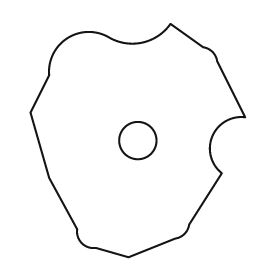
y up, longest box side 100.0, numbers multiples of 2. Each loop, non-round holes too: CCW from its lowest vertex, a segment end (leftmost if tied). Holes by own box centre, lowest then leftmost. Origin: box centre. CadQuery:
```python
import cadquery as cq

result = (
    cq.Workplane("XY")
    .moveTo(-4.0, -50.0)
    .lineTo(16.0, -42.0)
    .threePointArc((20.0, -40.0), (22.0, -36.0))
    .lineTo(36.0, -14.0)
    .threePointArc((32.0, 2.0), (46.0, 10.0))
    .lineTo(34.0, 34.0)
    .threePointArc((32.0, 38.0), (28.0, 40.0))
    .lineTo(14.0, 50.0)
    .threePointArc((2.0, 42.0), (-12.0, 44.0))
    .threePointArc((-30.0, 44.0), (-38.0, 28.0))
    .lineTo(-46.0, 12.0)
    .lineTo(-38.0, -16.0)
    .lineTo(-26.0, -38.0)
    .threePointArc((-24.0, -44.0), (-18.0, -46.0))
    .close()
    .moveTo(0.0, 0.0)
    .circle(8.0)
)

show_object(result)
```